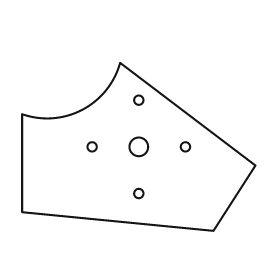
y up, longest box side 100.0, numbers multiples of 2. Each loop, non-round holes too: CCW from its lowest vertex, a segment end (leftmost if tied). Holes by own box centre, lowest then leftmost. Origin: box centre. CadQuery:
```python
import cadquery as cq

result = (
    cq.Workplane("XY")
    .moveTo(32.0, -36.0)
    .lineTo(50.0, -8.0)
    .lineTo(-8.0, 36.0)
    .threePointArc((-24.0, 16.0), (-50.0, 14.0))
    .lineTo(-50.0, -28.0)
    .close()
    .moveTo(0.0, -20.0)
    .circle(2.0)
    .moveTo(-20.0, 0.0)
    .circle(2.0)
    .moveTo(0.0, 0.0)
    .circle(4.0)
    .moveTo(20.0, 0.0)
    .circle(2.0)
    .moveTo(0.0, 20.0)
    .circle(2.0)
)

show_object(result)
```